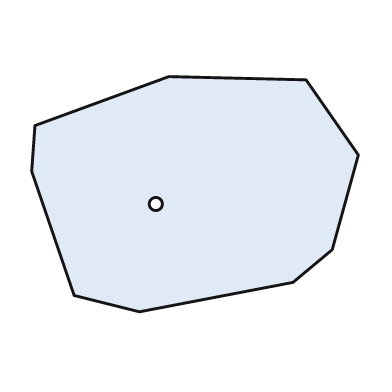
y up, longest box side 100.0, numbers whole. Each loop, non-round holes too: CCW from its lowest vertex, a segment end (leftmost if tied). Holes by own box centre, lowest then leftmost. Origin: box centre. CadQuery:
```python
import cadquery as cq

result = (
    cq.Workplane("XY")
    .moveTo(-17.0, -36.0)
    .lineTo(30.0, -27.0)
    .lineTo(42.0, -17.0)
    .lineTo(50.0, 12.0)
    .lineTo(34.0, 35.0)
    .lineTo(-8.0, 36.0)
    .lineTo(-49.0, 21.0)
    .lineTo(-50.0, 7.0)
    .lineTo(-37.0, -31.0)
    .close()
    .moveTo(-12.0, -3.0)
    .circle(2.0)
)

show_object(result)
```